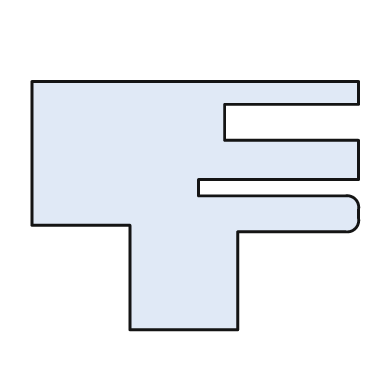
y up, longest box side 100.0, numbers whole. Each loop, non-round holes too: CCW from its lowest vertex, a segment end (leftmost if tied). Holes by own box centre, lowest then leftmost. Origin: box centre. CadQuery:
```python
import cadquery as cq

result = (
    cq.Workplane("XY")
    .moveTo(-20.0, -38.0)
    .lineTo(13.0, -38.0)
    .lineTo(13.0, -8.0)
    .lineTo(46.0, -8.0)
    .threePointArc((49.0, -7.0), (50.0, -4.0))
    .lineTo(50.0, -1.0)
    .threePointArc((49.0, 2.0), (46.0, 3.0))
    .lineTo(1.0, 3.0)
    .lineTo(1.0, 8.0)
    .lineTo(50.0, 8.0)
    .lineTo(50.0, 20.0)
    .lineTo(9.0, 20.0)
    .lineTo(9.0, 31.0)
    .lineTo(50.0, 31.0)
    .lineTo(50.0, 38.0)
    .lineTo(-50.0, 38.0)
    .lineTo(-50.0, -6.0)
    .lineTo(-20.0, -6.0)
    .close()
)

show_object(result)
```